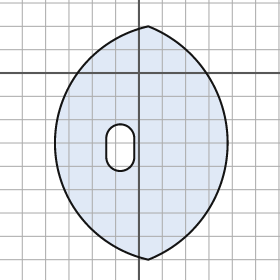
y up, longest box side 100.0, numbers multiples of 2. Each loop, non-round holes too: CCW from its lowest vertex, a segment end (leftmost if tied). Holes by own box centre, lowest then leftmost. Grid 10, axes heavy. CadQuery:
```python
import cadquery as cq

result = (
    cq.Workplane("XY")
    .moveTo(4.0, -80.0)
    .threePointArc((38.0, -30.0), (4.0, 20.0))
    .threePointArc((-36.0, -30.0), (4.0, -80.0))
    .close()
    .moveTo(-14.0, -36.0)
    .threePointArc((-8.0, -42.0), (-2.0, -36.0))
    .lineTo(-2.0, -28.0)
    .threePointArc((-8.0, -22.0), (-14.0, -28.0))
    .close()
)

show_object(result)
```